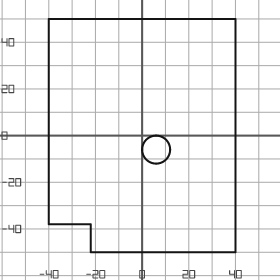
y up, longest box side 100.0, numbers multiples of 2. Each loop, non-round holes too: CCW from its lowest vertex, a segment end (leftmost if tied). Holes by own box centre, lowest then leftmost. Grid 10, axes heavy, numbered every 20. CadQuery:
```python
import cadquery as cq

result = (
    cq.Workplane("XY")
    .moveTo(-22.0, -50.0)
    .lineTo(40.0, -50.0)
    .lineTo(40.0, 50.0)
    .lineTo(-40.0, 50.0)
    .lineTo(-40.0, -38.0)
    .lineTo(-22.0, -38.0)
    .close()
    .moveTo(6.0, -6.0)
    .circle(6.0)
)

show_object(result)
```